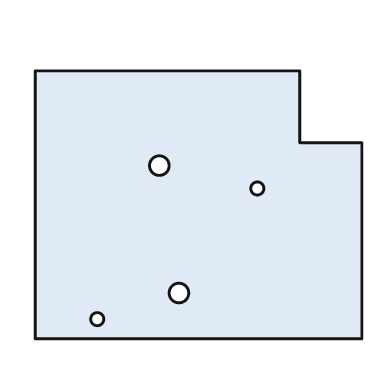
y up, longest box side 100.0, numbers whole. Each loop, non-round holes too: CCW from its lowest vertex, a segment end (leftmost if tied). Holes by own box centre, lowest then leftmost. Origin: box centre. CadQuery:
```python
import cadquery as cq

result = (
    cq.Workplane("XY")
    .moveTo(-50.0, -41.0)
    .lineTo(50.0, -41.0)
    .lineTo(50.0, 19.0)
    .lineTo(31.0, 19.0)
    .lineTo(31.0, 41.0)
    .lineTo(-50.0, 41.0)
    .close()
    .moveTo(-31.0, -35.0)
    .circle(2.0)
    .moveTo(-6.0, -27.0)
    .circle(3.0)
    .moveTo(18.0, 5.0)
    .circle(2.0)
    .moveTo(-12.0, 12.0)
    .circle(3.0)
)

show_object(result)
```